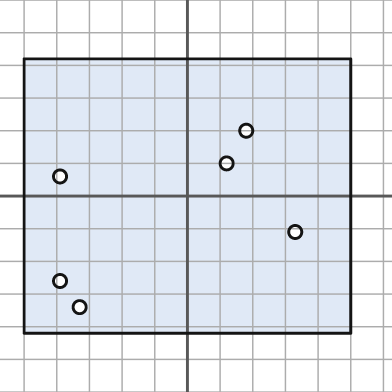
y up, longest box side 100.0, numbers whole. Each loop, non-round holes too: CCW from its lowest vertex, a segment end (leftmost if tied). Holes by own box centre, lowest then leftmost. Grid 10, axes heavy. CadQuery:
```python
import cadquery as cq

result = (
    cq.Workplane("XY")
    .moveTo(-50.0, -42.0)
    .lineTo(50.0, -42.0)
    .lineTo(50.0, 42.0)
    .lineTo(-50.0, 42.0)
    .close()
    .moveTo(-33.0, -34.0)
    .circle(2.0)
    .moveTo(-39.0, -26.0)
    .circle(2.0)
    .moveTo(33.0, -11.0)
    .circle(2.0)
    .moveTo(-39.0, 6.0)
    .circle(2.0)
    .moveTo(12.0, 10.0)
    .circle(2.0)
    .moveTo(18.0, 20.0)
    .circle(2.0)
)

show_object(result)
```